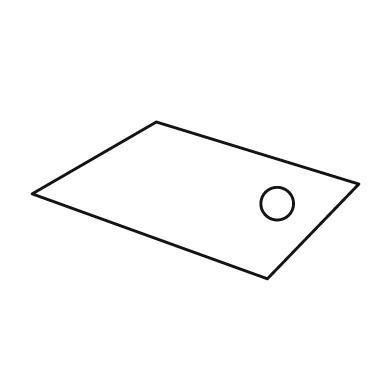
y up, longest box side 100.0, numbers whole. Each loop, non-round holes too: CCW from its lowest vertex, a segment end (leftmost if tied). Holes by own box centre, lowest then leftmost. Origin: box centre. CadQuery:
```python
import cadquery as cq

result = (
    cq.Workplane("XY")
    .moveTo(22.0, -24.0)
    .lineTo(50.0, 5.0)
    .lineTo(-12.0, 24.0)
    .lineTo(-50.0, 2.0)
    .close()
    .moveTo(25.0, -1.0)
    .circle(5.0)
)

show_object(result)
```